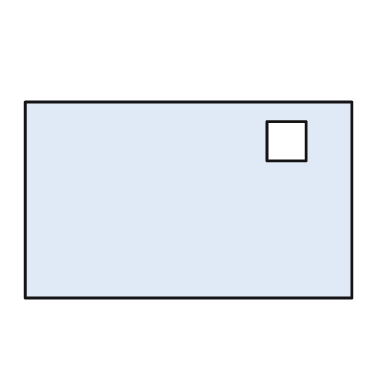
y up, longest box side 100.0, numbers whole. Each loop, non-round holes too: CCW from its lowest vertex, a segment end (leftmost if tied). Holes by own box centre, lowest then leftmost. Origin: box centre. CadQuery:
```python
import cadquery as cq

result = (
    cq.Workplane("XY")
    .moveTo(-50.0, -30.0)
    .lineTo(50.0, -30.0)
    .lineTo(50.0, 30.0)
    .lineTo(-50.0, 30.0)
    .close()
    .moveTo(24.0, 12.0)
    .lineTo(36.0, 12.0)
    .lineTo(36.0, 24.0)
    .lineTo(24.0, 24.0)
    .close()
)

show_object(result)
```